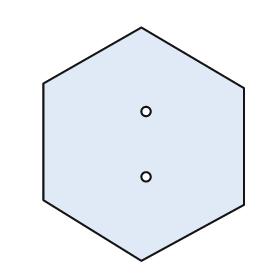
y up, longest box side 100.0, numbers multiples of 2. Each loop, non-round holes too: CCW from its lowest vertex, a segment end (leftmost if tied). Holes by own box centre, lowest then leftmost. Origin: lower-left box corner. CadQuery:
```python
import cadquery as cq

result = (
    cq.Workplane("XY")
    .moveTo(42.0, 0.0)
    .lineTo(86.0, 24.0)
    .lineTo(86.0, 74.0)
    .lineTo(42.0, 100.0)
    .lineTo(0.0, 76.0)
    .lineTo(0.0, 26.0)
    .close()
    .moveTo(44.0, 36.0)
    .circle(2.0)
    .moveTo(44.0, 64.0)
    .circle(2.0)
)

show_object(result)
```